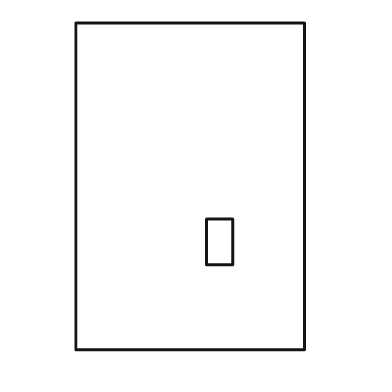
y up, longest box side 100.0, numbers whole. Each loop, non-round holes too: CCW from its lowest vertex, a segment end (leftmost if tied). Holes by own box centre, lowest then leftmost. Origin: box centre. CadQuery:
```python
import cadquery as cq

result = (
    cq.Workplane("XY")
    .moveTo(-35.0, -50.0)
    .lineTo(35.0, -50.0)
    .lineTo(35.0, 50.0)
    .lineTo(-35.0, 50.0)
    .close()
    .moveTo(5.0, -24.0)
    .lineTo(13.0, -24.0)
    .lineTo(13.0, -10.0)
    .lineTo(5.0, -10.0)
    .close()
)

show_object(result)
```